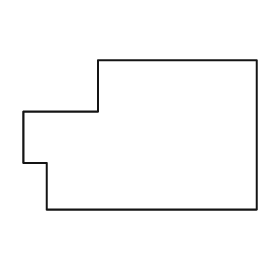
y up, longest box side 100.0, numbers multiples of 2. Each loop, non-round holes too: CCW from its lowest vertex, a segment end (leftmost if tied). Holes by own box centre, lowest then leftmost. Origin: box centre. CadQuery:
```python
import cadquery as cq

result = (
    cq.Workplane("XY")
    .moveTo(-40.0, -32.0)
    .lineTo(50.0, -32.0)
    .lineTo(50.0, 32.0)
    .lineTo(-18.0, 32.0)
    .lineTo(-18.0, 10.0)
    .lineTo(-50.0, 10.0)
    .lineTo(-50.0, -12.0)
    .lineTo(-40.0, -12.0)
    .close()
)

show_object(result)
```